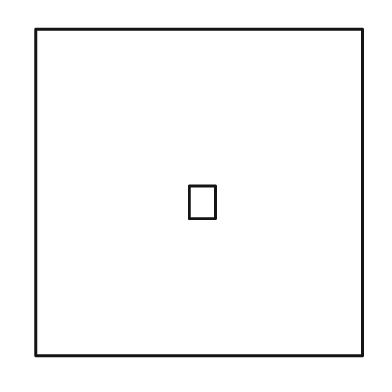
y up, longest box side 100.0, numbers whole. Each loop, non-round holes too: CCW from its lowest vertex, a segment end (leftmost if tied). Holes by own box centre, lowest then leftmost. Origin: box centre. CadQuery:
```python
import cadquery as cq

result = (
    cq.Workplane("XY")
    .moveTo(-50.0, -50.0)
    .lineTo(50.0, -50.0)
    .lineTo(50.0, 50.0)
    .lineTo(-50.0, 50.0)
    .close()
    .moveTo(-3.0, -8.0)
    .lineTo(5.0, -8.0)
    .lineTo(5.0, 2.0)
    .lineTo(-3.0, 2.0)
    .close()
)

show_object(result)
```